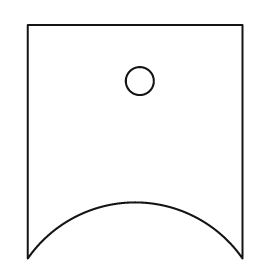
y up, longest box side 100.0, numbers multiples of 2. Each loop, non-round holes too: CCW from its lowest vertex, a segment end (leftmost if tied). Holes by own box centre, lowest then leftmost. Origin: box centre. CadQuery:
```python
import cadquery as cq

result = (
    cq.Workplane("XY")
    .moveTo(-46.0, -50.0)
    .threePointArc((0.0, -26.0), (46.0, -50.0))
    .lineTo(46.0, 50.0)
    .lineTo(-46.0, 50.0)
    .close()
    .moveTo(2.0, 26.0)
    .circle(6.0)
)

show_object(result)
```